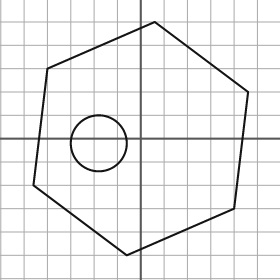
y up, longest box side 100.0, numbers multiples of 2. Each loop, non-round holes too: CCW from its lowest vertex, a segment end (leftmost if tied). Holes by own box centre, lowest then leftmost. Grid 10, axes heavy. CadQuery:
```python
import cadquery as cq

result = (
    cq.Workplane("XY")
    .moveTo(-6.0, -50.0)
    .lineTo(40.0, -30.0)
    .lineTo(46.0, 20.0)
    .lineTo(6.0, 50.0)
    .lineTo(-40.0, 30.0)
    .lineTo(-46.0, -20.0)
    .close()
    .moveTo(-18.0, -2.0)
    .circle(12.0)
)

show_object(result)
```